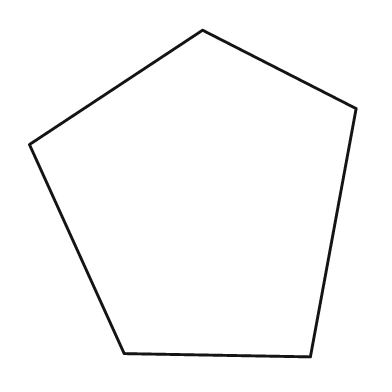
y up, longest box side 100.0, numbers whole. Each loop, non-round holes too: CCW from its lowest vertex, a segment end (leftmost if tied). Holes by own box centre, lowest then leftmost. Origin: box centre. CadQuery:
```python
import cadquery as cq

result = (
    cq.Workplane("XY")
    .moveTo(36.0, -50.0)
    .lineTo(50.0, 26.0)
    .lineTo(3.0, 50.0)
    .lineTo(-50.0, 15.0)
    .lineTo(-21.0, -49.0)
    .close()
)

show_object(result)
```